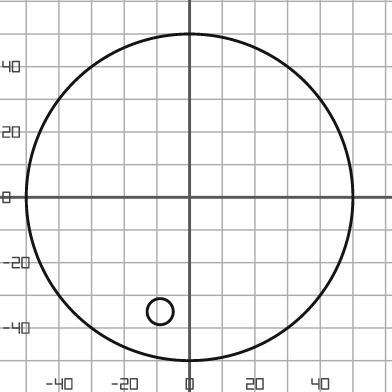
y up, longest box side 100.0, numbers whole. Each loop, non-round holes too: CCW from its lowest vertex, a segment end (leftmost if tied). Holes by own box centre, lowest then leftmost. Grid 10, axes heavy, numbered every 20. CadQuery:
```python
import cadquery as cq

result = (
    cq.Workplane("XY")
    .moveTo(0.0, 0.0)
    .circle(50.0)
    .moveTo(-9.0, -35.0)
    .circle(4.0)
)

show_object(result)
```